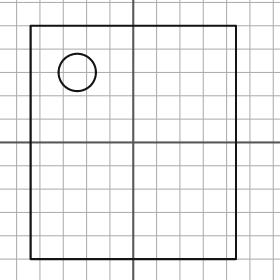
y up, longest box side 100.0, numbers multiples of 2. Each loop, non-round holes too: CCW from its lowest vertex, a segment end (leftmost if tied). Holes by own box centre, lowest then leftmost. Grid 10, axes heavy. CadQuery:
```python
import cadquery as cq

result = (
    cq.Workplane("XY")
    .moveTo(-44.0, -50.0)
    .lineTo(44.0, -50.0)
    .lineTo(44.0, 50.0)
    .lineTo(-44.0, 50.0)
    .close()
    .moveTo(-24.0, 30.0)
    .circle(8.0)
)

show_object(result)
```